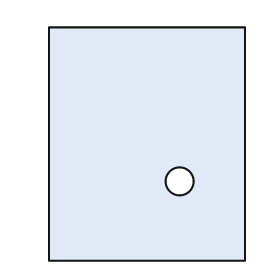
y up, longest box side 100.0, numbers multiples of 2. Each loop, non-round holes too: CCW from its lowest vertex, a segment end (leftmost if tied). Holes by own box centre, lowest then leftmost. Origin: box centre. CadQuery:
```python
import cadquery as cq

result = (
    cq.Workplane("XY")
    .moveTo(-42.0, -50.0)
    .lineTo(42.0, -50.0)
    .lineTo(42.0, 50.0)
    .lineTo(-42.0, 50.0)
    .close()
    .moveTo(14.0, -16.0)
    .circle(6.0)
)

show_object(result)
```